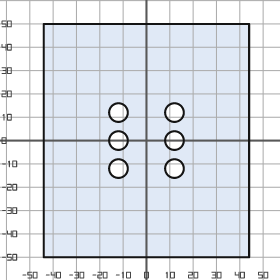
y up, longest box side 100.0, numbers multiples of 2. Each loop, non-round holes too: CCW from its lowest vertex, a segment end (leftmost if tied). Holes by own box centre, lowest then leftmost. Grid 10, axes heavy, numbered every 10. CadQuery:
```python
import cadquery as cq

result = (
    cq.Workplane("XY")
    .moveTo(-44.0, -50.0)
    .lineTo(44.0, -50.0)
    .lineTo(44.0, 50.0)
    .lineTo(-44.0, 50.0)
    .close()
    .moveTo(-12.0, -12.0)
    .circle(4.0)
    .moveTo(12.0, -12.0)
    .circle(4.0)
    .moveTo(-12.0, 0.0)
    .circle(4.0)
    .moveTo(12.0, 0.0)
    .circle(4.0)
    .moveTo(-12.0, 12.0)
    .circle(4.0)
    .moveTo(12.0, 12.0)
    .circle(4.0)
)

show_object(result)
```